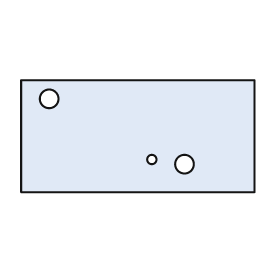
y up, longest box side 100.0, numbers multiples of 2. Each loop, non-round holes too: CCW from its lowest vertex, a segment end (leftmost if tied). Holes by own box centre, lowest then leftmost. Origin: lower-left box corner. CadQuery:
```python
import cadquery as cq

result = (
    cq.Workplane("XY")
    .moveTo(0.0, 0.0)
    .lineTo(100.0, 0.0)
    .lineTo(100.0, 48.0)
    .lineTo(0.0, 48.0)
    .close()
    .moveTo(70.0, 12.0)
    .circle(4.0)
    .moveTo(56.0, 14.0)
    .circle(2.0)
    .moveTo(12.0, 40.0)
    .circle(4.0)
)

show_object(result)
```